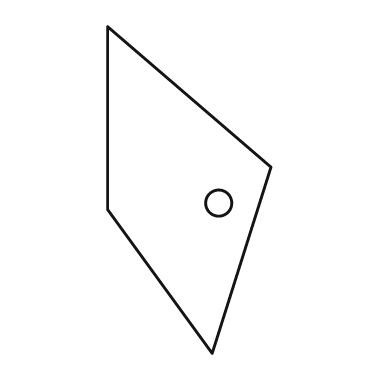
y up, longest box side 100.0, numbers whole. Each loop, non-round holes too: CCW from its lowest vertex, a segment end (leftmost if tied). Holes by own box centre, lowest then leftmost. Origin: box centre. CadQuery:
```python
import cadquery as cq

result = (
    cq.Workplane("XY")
    .moveTo(7.0, -50.0)
    .lineTo(25.0, 7.0)
    .lineTo(-25.0, 50.0)
    .lineTo(-25.0, -6.0)
    .close()
    .moveTo(9.0, -4.0)
    .circle(4.0)
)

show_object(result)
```